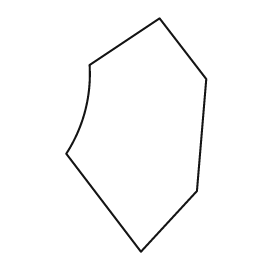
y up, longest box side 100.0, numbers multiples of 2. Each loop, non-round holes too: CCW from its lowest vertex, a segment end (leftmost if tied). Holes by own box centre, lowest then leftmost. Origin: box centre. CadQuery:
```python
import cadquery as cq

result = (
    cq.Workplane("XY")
    .moveTo(2.0, -50.0)
    .lineTo(26.0, -24.0)
    .lineTo(30.0, 24.0)
    .lineTo(10.0, 50.0)
    .lineTo(-20.0, 30.0)
    .threePointArc((-22.0, 10.0), (-30.0, -8.0))
    .close()
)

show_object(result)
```